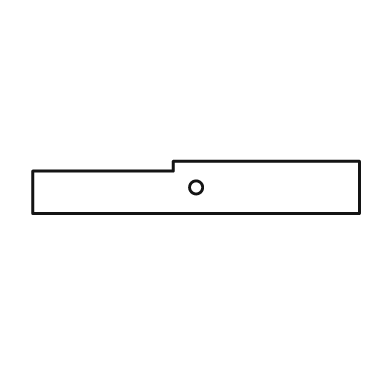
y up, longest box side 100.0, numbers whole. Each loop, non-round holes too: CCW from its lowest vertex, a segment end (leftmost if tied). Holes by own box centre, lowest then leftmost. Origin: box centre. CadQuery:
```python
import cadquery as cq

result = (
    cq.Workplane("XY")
    .moveTo(-50.0, -8.0)
    .lineTo(50.0, -8.0)
    .lineTo(50.0, 8.0)
    .lineTo(-7.0, 8.0)
    .lineTo(-7.0, 5.0)
    .lineTo(-50.0, 5.0)
    .close()
    .moveTo(0.0, 0.0)
    .circle(2.0)
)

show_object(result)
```